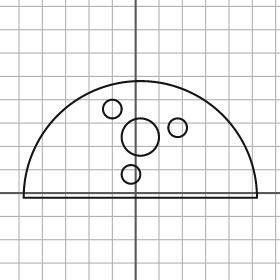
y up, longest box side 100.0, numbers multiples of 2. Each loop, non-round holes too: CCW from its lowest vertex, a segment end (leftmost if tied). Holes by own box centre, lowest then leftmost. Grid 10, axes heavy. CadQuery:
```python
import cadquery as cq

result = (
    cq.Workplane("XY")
    .moveTo(-48.0, -2.0)
    .lineTo(52.0, -2.0)
    .threePointArc((2.0, 48.0), (-48.0, -2.0))
    .close()
    .moveTo(-2.0, 8.0)
    .circle(4.0)
    .moveTo(2.0, 24.0)
    .circle(8.0)
    .moveTo(18.0, 28.0)
    .circle(4.0)
    .moveTo(-10.0, 36.0)
    .circle(4.0)
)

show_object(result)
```